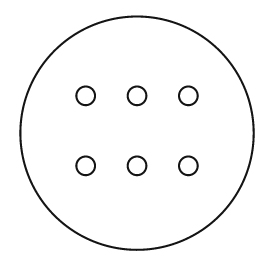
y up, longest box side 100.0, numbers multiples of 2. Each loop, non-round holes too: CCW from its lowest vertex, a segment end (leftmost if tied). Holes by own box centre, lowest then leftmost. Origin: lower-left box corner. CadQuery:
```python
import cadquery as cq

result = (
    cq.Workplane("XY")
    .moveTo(50.0, 50.0)
    .circle(50.0)
    .moveTo(28.0, 36.0)
    .circle(4.0)
    .moveTo(50.0, 36.0)
    .circle(4.0)
    .moveTo(72.0, 36.0)
    .circle(4.0)
    .moveTo(28.0, 66.0)
    .circle(4.0)
    .moveTo(50.0, 66.0)
    .circle(4.0)
    .moveTo(72.0, 66.0)
    .circle(4.0)
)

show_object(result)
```